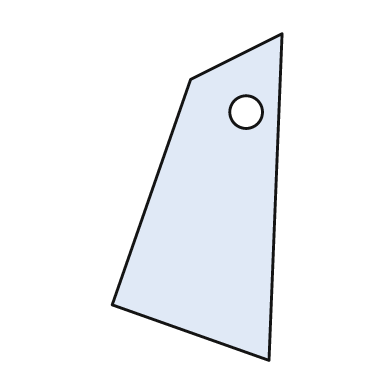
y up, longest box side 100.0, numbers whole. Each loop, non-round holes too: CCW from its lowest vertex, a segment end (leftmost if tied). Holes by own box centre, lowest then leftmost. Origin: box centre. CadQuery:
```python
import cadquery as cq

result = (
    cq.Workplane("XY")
    .moveTo(22.0, -50.0)
    .lineTo(26.0, 50.0)
    .lineTo(-2.0, 36.0)
    .lineTo(-26.0, -33.0)
    .close()
    .moveTo(15.0, 26.0)
    .circle(5.0)
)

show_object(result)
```